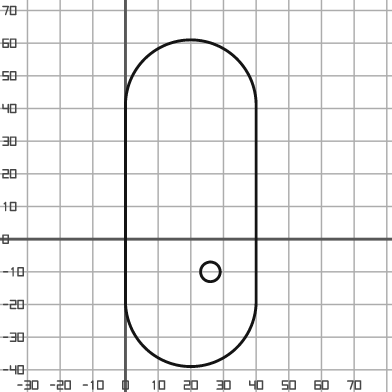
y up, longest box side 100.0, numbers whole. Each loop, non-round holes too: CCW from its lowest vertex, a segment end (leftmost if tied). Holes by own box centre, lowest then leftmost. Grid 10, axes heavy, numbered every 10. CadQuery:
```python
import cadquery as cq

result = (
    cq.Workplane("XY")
    .moveTo(0.0, -19.0)
    .threePointArc((20.0, -39.0), (40.0, -19.0))
    .lineTo(40.0, 41.0)
    .threePointArc((20.0, 61.0), (0.0, 41.0))
    .close()
    .moveTo(26.0, -10.0)
    .circle(3.0)
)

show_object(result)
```